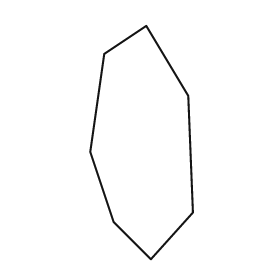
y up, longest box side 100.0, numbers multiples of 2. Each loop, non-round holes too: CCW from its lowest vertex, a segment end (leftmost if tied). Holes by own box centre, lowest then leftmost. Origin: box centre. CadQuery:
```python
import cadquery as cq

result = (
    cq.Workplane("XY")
    .moveTo(4.0, -50.0)
    .lineTo(22.0, -30.0)
    .lineTo(20.0, 20.0)
    .lineTo(2.0, 50.0)
    .lineTo(-16.0, 38.0)
    .lineTo(-22.0, -4.0)
    .lineTo(-12.0, -34.0)
    .close()
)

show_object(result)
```